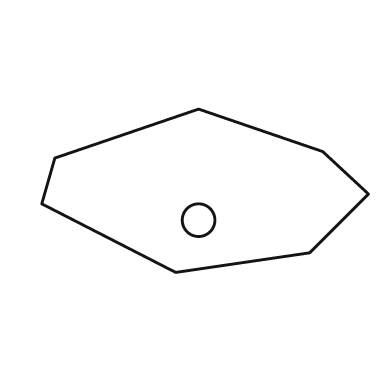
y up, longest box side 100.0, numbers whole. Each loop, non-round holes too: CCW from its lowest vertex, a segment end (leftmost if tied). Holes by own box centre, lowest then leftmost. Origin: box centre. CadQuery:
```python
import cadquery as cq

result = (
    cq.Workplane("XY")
    .moveTo(-9.0, -25.0)
    .lineTo(32.0, -19.0)
    .lineTo(50.0, -1.0)
    .lineTo(36.0, 12.0)
    .lineTo(-2.0, 25.0)
    .lineTo(-46.0, 10.0)
    .lineTo(-50.0, -4.0)
    .close()
    .moveTo(-2.0, -9.0)
    .circle(5.0)
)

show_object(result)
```